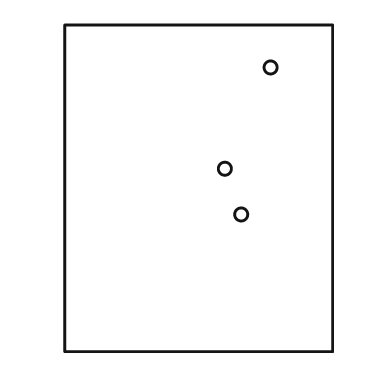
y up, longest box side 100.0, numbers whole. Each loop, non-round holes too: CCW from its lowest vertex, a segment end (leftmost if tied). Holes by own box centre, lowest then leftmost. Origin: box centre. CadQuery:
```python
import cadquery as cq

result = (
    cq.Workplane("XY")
    .moveTo(-41.0, -50.0)
    .lineTo(41.0, -50.0)
    .lineTo(41.0, 50.0)
    .lineTo(-41.0, 50.0)
    .close()
    .moveTo(13.0, -8.0)
    .circle(2.0)
    .moveTo(8.0, 6.0)
    .circle(2.0)
    .moveTo(22.0, 37.0)
    .circle(2.0)
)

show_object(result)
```